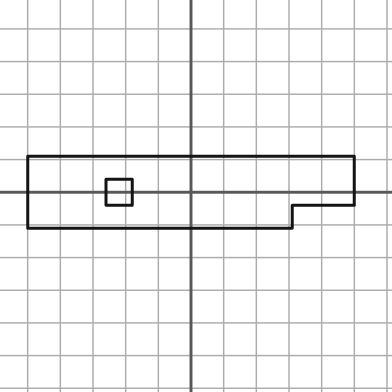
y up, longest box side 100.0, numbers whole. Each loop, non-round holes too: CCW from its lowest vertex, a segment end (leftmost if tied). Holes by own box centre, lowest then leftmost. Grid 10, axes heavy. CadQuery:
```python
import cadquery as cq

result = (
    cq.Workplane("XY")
    .moveTo(-50.0, -11.0)
    .lineTo(31.0, -11.0)
    .lineTo(31.0, -4.0)
    .lineTo(50.0, -4.0)
    .lineTo(50.0, 11.0)
    .lineTo(-50.0, 11.0)
    .close()
    .moveTo(-26.0, -4.0)
    .lineTo(-18.0, -4.0)
    .lineTo(-18.0, 4.0)
    .lineTo(-26.0, 4.0)
    .close()
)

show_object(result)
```